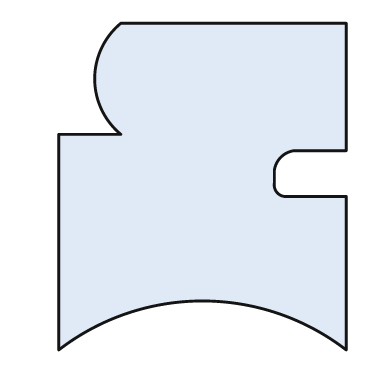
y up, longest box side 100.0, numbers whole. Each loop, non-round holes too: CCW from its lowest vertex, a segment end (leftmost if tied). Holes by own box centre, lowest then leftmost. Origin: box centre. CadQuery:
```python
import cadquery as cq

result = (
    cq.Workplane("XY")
    .moveTo(-44.0, -50.0)
    .threePointArc((0.0, -35.0), (44.0, -50.0))
    .lineTo(44.0, -3.0)
    .lineTo(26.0, -3.0)
    .threePointArc((23.0, -2.0), (22.0, 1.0))
    .lineTo(22.0, 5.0)
    .threePointArc((24.0, 9.0), (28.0, 11.0))
    .lineTo(44.0, 11.0)
    .lineTo(44.0, 50.0)
    .lineTo(-25.0, 50.0)
    .threePointArc((-33.0, 33.0), (-25.0, 16.0))
    .lineTo(-44.0, 16.0)
    .close()
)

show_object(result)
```